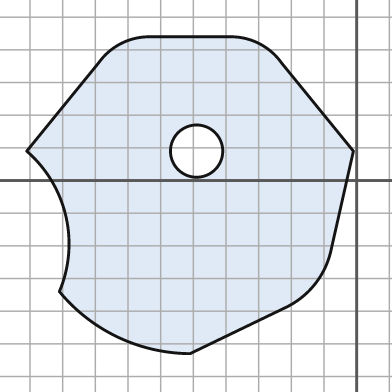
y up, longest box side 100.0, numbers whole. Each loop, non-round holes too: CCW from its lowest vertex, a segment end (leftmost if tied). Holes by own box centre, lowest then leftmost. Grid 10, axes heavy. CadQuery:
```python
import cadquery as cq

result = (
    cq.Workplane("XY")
    .moveTo(-51.0, -53.0)
    .lineTo(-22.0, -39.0)
    .threePointArc((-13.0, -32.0), (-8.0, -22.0))
    .lineTo(-1.0, 9.0)
    .lineTo(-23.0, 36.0)
    .threePointArc((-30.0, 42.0), (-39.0, 44.0))
    .lineTo(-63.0, 44.0)
    .threePointArc((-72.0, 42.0), (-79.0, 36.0))
    .lineTo(-101.0, 9.0)
    .threePointArc((-89.0, -11.0), (-91.0, -34.0))
    .threePointArc((-73.0, -48.0), (-51.0, -53.0))
    .close()
    .moveTo(-49.0, 9.0)
    .circle(8.0)
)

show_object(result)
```